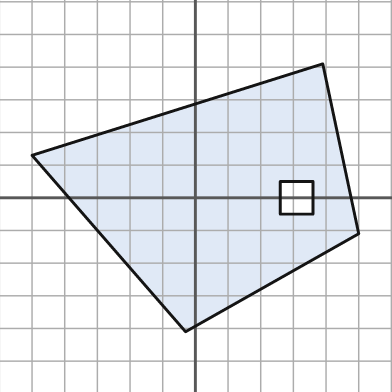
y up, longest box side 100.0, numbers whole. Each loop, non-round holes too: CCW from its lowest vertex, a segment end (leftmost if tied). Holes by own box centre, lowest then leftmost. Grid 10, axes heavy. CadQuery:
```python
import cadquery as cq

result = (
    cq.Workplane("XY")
    .moveTo(-3.0, -41.0)
    .lineTo(50.0, -11.0)
    .lineTo(39.0, 41.0)
    .lineTo(-50.0, 13.0)
    .close()
    .moveTo(26.0, -5.0)
    .lineTo(36.0, -5.0)
    .lineTo(36.0, 5.0)
    .lineTo(26.0, 5.0)
    .close()
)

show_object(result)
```